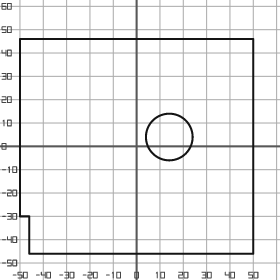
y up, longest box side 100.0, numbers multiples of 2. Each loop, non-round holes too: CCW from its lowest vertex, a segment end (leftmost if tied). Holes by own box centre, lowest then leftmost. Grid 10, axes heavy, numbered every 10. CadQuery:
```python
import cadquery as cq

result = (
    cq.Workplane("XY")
    .moveTo(-46.0, -46.0)
    .lineTo(50.0, -46.0)
    .lineTo(50.0, 46.0)
    .lineTo(-50.0, 46.0)
    .lineTo(-50.0, -30.0)
    .lineTo(-46.0, -30.0)
    .close()
    .moveTo(14.0, 4.0)
    .circle(10.0)
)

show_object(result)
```